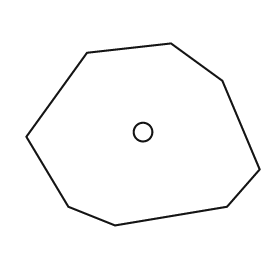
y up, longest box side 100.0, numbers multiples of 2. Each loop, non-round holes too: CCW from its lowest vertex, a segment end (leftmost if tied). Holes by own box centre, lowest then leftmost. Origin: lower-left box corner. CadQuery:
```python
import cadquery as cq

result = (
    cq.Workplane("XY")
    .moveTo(38.0, 0.0)
    .lineTo(86.0, 8.0)
    .lineTo(100.0, 24.0)
    .lineTo(84.0, 62.0)
    .lineTo(62.0, 78.0)
    .lineTo(26.0, 74.0)
    .lineTo(0.0, 38.0)
    .lineTo(18.0, 8.0)
    .close()
    .moveTo(50.0, 40.0)
    .circle(4.0)
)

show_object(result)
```